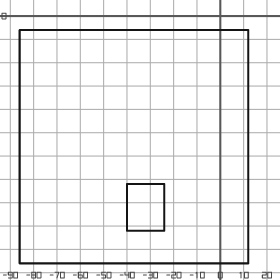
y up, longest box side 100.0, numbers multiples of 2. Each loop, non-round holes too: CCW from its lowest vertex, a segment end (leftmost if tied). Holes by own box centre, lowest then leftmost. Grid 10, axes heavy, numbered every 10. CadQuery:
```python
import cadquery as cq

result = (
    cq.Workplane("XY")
    .moveTo(-86.0, -106.0)
    .lineTo(12.0, -106.0)
    .lineTo(12.0, -6.0)
    .lineTo(-86.0, -6.0)
    .close()
    .moveTo(-40.0, -92.0)
    .lineTo(-24.0, -92.0)
    .lineTo(-24.0, -72.0)
    .lineTo(-40.0, -72.0)
    .close()
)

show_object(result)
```